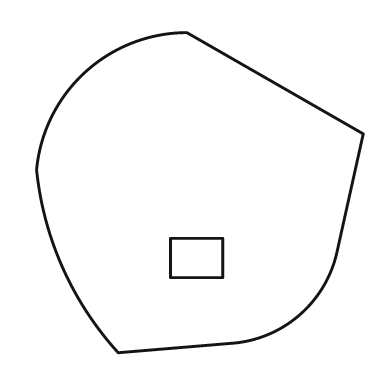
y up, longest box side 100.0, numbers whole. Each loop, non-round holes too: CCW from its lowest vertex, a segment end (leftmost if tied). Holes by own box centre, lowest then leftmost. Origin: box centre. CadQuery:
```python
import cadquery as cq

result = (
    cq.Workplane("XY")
    .moveTo(-25.0, -49.0)
    .lineTo(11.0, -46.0)
    .threePointArc((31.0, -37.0), (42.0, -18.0))
    .lineTo(50.0, 18.0)
    .lineTo(-4.0, 49.0)
    .threePointArc((-35.0, 37.0), (-50.0, 7.0))
    .threePointArc((-42.0, -23.0), (-25.0, -49.0))
    .close()
    .moveTo(-9.0, -26.0)
    .lineTo(7.0, -26.0)
    .lineTo(7.0, -14.0)
    .lineTo(-9.0, -14.0)
    .close()
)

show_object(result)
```